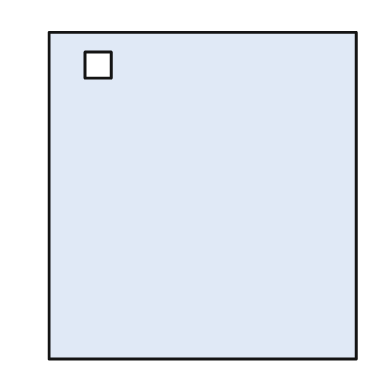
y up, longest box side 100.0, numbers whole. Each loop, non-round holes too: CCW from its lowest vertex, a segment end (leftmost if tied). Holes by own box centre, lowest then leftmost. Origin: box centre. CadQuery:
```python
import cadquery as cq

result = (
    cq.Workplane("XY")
    .moveTo(-47.0, -50.0)
    .lineTo(47.0, -50.0)
    .lineTo(47.0, 50.0)
    .lineTo(-47.0, 50.0)
    .close()
    .moveTo(-36.0, 36.0)
    .lineTo(-28.0, 36.0)
    .lineTo(-28.0, 44.0)
    .lineTo(-36.0, 44.0)
    .close()
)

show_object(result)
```